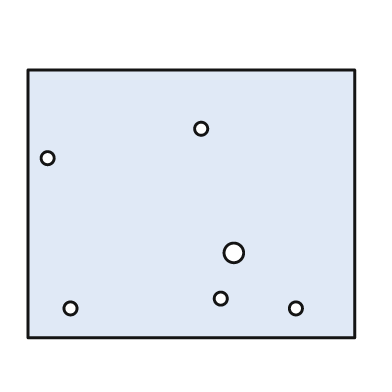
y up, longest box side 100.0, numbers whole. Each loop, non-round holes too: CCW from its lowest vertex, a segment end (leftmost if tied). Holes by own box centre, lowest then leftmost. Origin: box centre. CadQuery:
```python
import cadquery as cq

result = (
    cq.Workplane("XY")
    .moveTo(-50.0, -41.0)
    .lineTo(50.0, -41.0)
    .lineTo(50.0, 41.0)
    .lineTo(-50.0, 41.0)
    .close()
    .moveTo(-37.0, -32.0)
    .circle(2.0)
    .moveTo(32.0, -32.0)
    .circle(2.0)
    .moveTo(9.0, -29.0)
    .circle(2.0)
    .moveTo(13.0, -15.0)
    .circle(3.0)
    .moveTo(-44.0, 14.0)
    .circle(2.0)
    .moveTo(3.0, 23.0)
    .circle(2.0)
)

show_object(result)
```